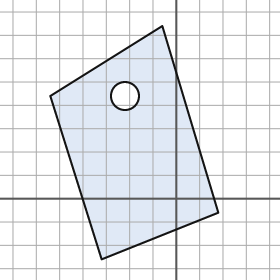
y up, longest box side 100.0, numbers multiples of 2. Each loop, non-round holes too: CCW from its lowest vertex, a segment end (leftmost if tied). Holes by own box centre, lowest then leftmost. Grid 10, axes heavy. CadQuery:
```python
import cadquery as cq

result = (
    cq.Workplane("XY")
    .moveTo(-32.0, -26.0)
    .lineTo(18.0, -6.0)
    .lineTo(-6.0, 74.0)
    .lineTo(-54.0, 44.0)
    .close()
    .moveTo(-22.0, 44.0)
    .circle(6.0)
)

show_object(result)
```